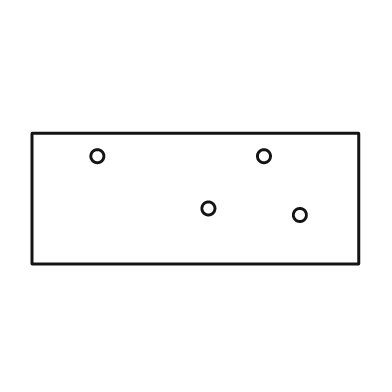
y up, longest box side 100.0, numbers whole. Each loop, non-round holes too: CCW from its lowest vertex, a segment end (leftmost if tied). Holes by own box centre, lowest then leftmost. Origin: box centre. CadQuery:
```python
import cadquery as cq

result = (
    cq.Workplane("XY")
    .moveTo(-50.0, -20.0)
    .lineTo(50.0, -20.0)
    .lineTo(50.0, 20.0)
    .lineTo(-50.0, 20.0)
    .close()
    .moveTo(32.0, -5.0)
    .circle(2.0)
    .moveTo(4.0, -3.0)
    .circle(2.0)
    .moveTo(-30.0, 13.0)
    .circle(2.0)
    .moveTo(21.0, 13.0)
    .circle(2.0)
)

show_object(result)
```